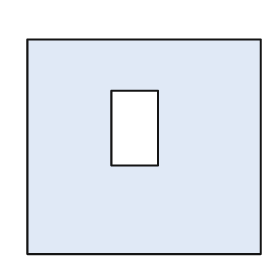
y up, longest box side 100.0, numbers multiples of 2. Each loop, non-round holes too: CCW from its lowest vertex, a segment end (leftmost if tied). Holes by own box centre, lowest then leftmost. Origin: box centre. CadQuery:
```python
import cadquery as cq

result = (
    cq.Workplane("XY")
    .moveTo(-50.0, -46.0)
    .lineTo(50.0, -46.0)
    .lineTo(50.0, 46.0)
    .lineTo(-50.0, 46.0)
    .close()
    .moveTo(-14.0, -8.0)
    .lineTo(6.0, -8.0)
    .lineTo(6.0, 24.0)
    .lineTo(-14.0, 24.0)
    .close()
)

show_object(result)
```